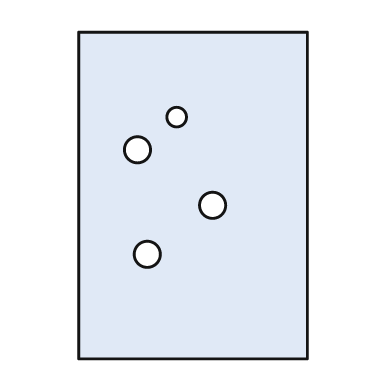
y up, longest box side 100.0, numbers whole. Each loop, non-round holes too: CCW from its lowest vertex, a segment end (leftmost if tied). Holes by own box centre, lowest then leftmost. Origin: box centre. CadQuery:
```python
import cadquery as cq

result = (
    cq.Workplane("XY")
    .moveTo(-35.0, -50.0)
    .lineTo(35.0, -50.0)
    .lineTo(35.0, 50.0)
    .lineTo(-35.0, 50.0)
    .close()
    .moveTo(-14.0, -18.0)
    .circle(4.0)
    .moveTo(6.0, -3.0)
    .circle(4.0)
    .moveTo(-17.0, 14.0)
    .circle(4.0)
    .moveTo(-5.0, 24.0)
    .circle(3.0)
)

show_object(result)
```